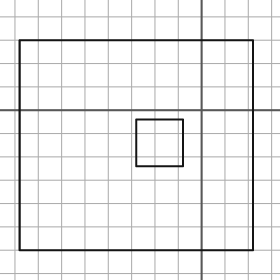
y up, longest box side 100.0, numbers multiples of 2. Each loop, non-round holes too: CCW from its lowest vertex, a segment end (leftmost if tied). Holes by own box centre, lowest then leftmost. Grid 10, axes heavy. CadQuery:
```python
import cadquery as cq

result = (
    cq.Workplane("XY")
    .moveTo(-78.0, -60.0)
    .lineTo(22.0, -60.0)
    .lineTo(22.0, 30.0)
    .lineTo(-78.0, 30.0)
    .close()
    .moveTo(-28.0, -24.0)
    .lineTo(-8.0, -24.0)
    .lineTo(-8.0, -4.0)
    .lineTo(-28.0, -4.0)
    .close()
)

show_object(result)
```